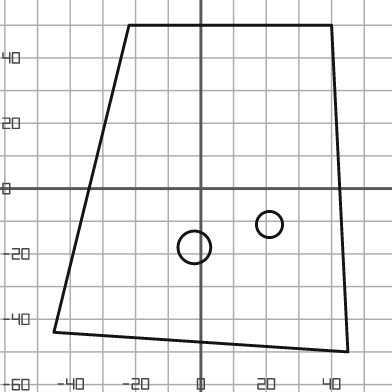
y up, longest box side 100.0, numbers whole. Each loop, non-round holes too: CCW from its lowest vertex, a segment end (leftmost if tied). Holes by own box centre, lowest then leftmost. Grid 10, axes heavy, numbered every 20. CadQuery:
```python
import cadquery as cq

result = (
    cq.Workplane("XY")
    .moveTo(45.0, -50.0)
    .lineTo(40.0, 50.0)
    .lineTo(-22.0, 50.0)
    .lineTo(-45.0, -44.0)
    .close()
    .moveTo(-2.0, -18.0)
    .circle(5.0)
    .moveTo(21.0, -11.0)
    .circle(4.0)
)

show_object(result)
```